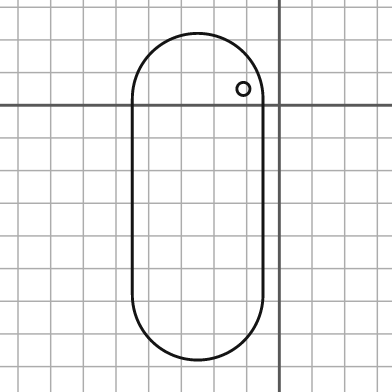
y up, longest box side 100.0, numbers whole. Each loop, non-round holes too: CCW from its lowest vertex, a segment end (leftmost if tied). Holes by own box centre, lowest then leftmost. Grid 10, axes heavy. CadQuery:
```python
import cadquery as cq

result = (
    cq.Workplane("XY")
    .moveTo(-45.0, -58.0)
    .threePointArc((-25.0, -78.0), (-5.0, -58.0))
    .lineTo(-5.0, 2.0)
    .threePointArc((-25.0, 22.0), (-45.0, 2.0))
    .close()
    .moveTo(-11.0, 5.0)
    .circle(2.0)
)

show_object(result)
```